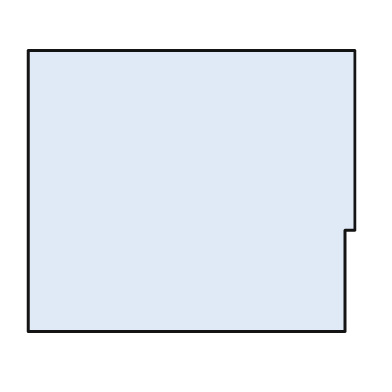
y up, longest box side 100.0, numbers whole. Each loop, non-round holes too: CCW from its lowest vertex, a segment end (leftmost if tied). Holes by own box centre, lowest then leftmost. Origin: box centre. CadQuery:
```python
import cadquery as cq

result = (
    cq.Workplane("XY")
    .moveTo(-50.0, -43.0)
    .lineTo(47.0, -43.0)
    .lineTo(47.0, -12.0)
    .lineTo(50.0, -12.0)
    .lineTo(50.0, 43.0)
    .lineTo(-50.0, 43.0)
    .close()
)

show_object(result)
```